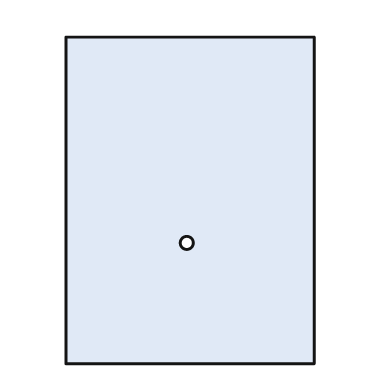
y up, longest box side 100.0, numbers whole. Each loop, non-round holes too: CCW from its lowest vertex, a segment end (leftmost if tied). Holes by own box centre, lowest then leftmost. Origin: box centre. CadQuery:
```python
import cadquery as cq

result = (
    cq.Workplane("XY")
    .moveTo(-38.0, -50.0)
    .lineTo(38.0, -50.0)
    .lineTo(38.0, 50.0)
    .lineTo(-38.0, 50.0)
    .close()
    .moveTo(-1.0, -13.0)
    .circle(2.0)
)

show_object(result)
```